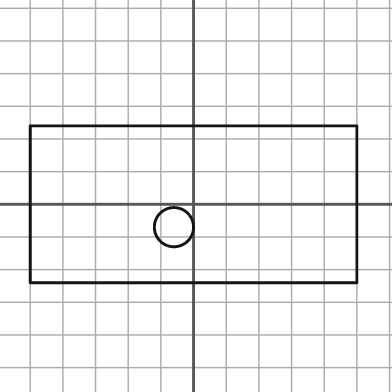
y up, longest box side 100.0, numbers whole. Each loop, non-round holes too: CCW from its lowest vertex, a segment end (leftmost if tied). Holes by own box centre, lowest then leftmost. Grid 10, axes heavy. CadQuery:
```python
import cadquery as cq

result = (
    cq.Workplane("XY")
    .moveTo(-50.0, -24.0)
    .lineTo(50.0, -24.0)
    .lineTo(50.0, 24.0)
    .lineTo(-50.0, 24.0)
    .close()
    .moveTo(-6.0, -7.0)
    .circle(6.0)
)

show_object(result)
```